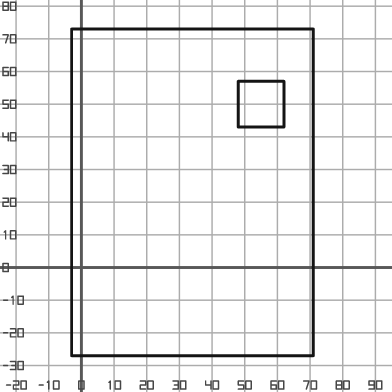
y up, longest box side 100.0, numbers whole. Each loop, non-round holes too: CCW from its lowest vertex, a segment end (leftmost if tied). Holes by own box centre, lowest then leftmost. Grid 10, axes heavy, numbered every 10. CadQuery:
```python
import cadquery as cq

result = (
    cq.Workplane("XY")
    .moveTo(-3.0, -27.0)
    .lineTo(71.0, -27.0)
    .lineTo(71.0, 73.0)
    .lineTo(-3.0, 73.0)
    .close()
    .moveTo(48.0, 43.0)
    .lineTo(62.0, 43.0)
    .lineTo(62.0, 57.0)
    .lineTo(48.0, 57.0)
    .close()
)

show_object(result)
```